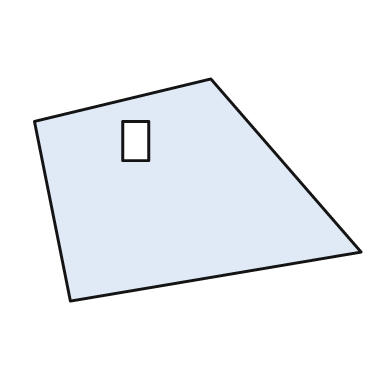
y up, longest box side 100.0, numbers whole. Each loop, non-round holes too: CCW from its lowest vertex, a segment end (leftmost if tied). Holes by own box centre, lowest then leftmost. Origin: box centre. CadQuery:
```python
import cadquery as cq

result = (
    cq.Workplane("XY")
    .moveTo(-39.0, -34.0)
    .lineTo(50.0, -19.0)
    .lineTo(4.0, 34.0)
    .lineTo(-50.0, 21.0)
    .close()
    .moveTo(-23.0, 9.0)
    .lineTo(-15.0, 9.0)
    .lineTo(-15.0, 21.0)
    .lineTo(-23.0, 21.0)
    .close()
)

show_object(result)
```